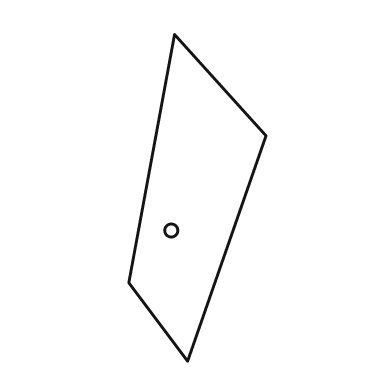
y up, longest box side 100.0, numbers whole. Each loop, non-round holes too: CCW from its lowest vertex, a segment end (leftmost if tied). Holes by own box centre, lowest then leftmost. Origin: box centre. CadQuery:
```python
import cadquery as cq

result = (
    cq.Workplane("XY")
    .moveTo(-3.0, -50.0)
    .lineTo(21.0, 19.0)
    .lineTo(-7.0, 50.0)
    .lineTo(-21.0, -26.0)
    .close()
    .moveTo(-8.0, -10.0)
    .circle(2.0)
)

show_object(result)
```